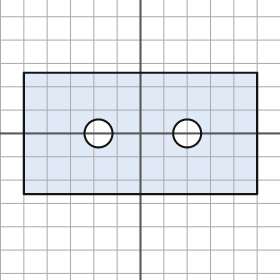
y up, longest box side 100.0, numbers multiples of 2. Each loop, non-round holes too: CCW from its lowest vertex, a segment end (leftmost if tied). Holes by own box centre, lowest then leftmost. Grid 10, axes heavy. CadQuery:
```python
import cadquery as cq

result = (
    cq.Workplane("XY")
    .moveTo(-50.0, -26.0)
    .lineTo(50.0, -26.0)
    .lineTo(50.0, 26.0)
    .lineTo(-50.0, 26.0)
    .close()
    .moveTo(-18.0, 0.0)
    .circle(6.0)
    .moveTo(20.0, 0.0)
    .circle(6.0)
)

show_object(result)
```